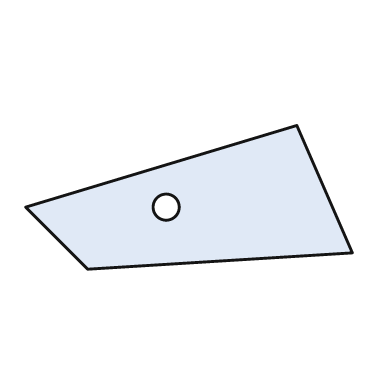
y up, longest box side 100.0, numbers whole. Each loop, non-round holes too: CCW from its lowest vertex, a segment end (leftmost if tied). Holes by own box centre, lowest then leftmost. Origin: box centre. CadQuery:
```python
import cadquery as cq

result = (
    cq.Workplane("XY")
    .moveTo(-31.0, -22.0)
    .lineTo(50.0, -17.0)
    .lineTo(33.0, 22.0)
    .lineTo(-50.0, -3.0)
    .close()
    .moveTo(-7.0, -3.0)
    .circle(4.0)
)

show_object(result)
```